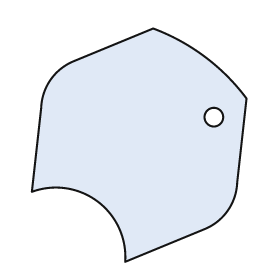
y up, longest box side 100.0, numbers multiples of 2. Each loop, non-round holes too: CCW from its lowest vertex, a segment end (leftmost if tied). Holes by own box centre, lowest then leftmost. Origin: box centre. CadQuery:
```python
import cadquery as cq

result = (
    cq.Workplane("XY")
    .moveTo(-6.0, -50.0)
    .lineTo(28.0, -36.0)
    .threePointArc((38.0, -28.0), (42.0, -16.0))
    .lineTo(46.0, 20.0)
    .threePointArc((28.0, 38.0), (6.0, 50.0))
    .lineTo(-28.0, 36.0)
    .threePointArc((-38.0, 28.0), (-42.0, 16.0))
    .lineTo(-46.0, -20.0)
    .threePointArc((-18.0, -24.0), (-6.0, -50.0))
    .close()
    .moveTo(32.0, 12.0)
    .circle(4.0)
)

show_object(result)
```